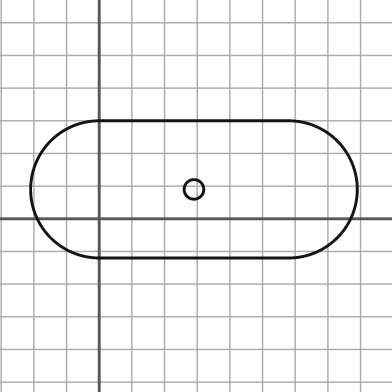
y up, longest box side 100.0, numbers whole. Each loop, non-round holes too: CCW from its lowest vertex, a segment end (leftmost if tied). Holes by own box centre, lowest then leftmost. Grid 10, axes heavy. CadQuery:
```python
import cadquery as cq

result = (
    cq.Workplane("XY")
    .moveTo(0.0, -12.0)
    .lineTo(58.0, -12.0)
    .threePointArc((79.0, 9.0), (58.0, 30.0))
    .lineTo(0.0, 30.0)
    .threePointArc((-21.0, 9.0), (0.0, -12.0))
    .close()
    .moveTo(29.0, 9.0)
    .circle(3.0)
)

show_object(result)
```